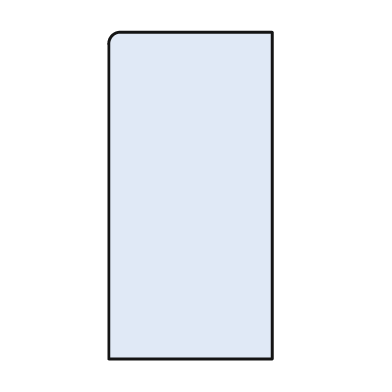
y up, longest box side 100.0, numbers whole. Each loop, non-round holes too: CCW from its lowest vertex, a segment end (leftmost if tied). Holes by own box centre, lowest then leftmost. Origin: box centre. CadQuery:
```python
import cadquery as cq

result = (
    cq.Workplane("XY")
    .moveTo(-25.0, -50.0)
    .lineTo(25.0, -50.0)
    .lineTo(25.0, 50.0)
    .lineTo(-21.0, 50.0)
    .threePointArc((-24.0, 49.0), (-25.0, 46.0))
    .close()
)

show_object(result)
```